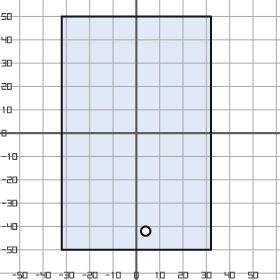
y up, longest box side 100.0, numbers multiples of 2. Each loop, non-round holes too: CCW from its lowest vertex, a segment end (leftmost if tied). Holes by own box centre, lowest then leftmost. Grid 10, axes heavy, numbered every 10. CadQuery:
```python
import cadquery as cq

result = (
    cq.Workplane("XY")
    .moveTo(-32.0, -50.0)
    .lineTo(32.0, -50.0)
    .lineTo(32.0, 50.0)
    .lineTo(-32.0, 50.0)
    .close()
    .moveTo(4.0, -42.0)
    .circle(2.0)
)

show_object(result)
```